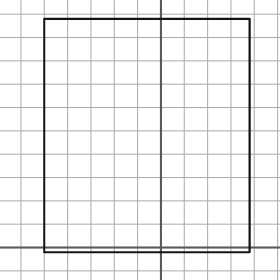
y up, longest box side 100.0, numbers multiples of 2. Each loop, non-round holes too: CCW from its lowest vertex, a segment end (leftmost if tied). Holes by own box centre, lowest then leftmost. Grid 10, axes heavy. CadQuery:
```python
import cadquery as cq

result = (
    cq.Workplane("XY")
    .moveTo(-50.0, -2.0)
    .lineTo(38.0, -2.0)
    .lineTo(38.0, 98.0)
    .lineTo(-50.0, 98.0)
    .close()
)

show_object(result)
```